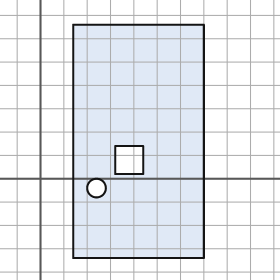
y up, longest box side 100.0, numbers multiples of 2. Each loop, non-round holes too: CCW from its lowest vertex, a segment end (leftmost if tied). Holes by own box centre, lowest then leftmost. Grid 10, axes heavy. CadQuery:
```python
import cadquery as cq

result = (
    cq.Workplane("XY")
    .moveTo(14.0, -34.0)
    .lineTo(70.0, -34.0)
    .lineTo(70.0, 66.0)
    .lineTo(14.0, 66.0)
    .close()
    .moveTo(24.0, -4.0)
    .circle(4.0)
    .moveTo(32.0, 2.0)
    .lineTo(44.0, 2.0)
    .lineTo(44.0, 14.0)
    .lineTo(32.0, 14.0)
    .close()
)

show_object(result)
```